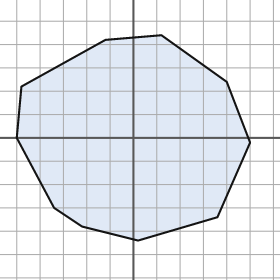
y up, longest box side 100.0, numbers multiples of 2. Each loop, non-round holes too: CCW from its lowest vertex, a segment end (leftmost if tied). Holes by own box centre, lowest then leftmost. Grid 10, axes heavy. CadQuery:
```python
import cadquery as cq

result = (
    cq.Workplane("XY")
    .moveTo(2.0, -44.0)
    .lineTo(36.0, -34.0)
    .lineTo(50.0, -2.0)
    .lineTo(40.0, 24.0)
    .lineTo(12.0, 44.0)
    .lineTo(-12.0, 42.0)
    .lineTo(-48.0, 22.0)
    .lineTo(-50.0, 0.0)
    .lineTo(-34.0, -30.0)
    .lineTo(-22.0, -38.0)
    .close()
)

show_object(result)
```